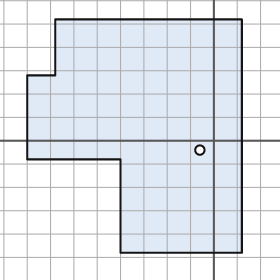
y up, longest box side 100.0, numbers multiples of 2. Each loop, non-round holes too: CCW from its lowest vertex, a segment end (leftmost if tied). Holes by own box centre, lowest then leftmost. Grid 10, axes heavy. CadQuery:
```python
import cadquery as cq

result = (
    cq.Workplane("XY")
    .moveTo(-40.0, -48.0)
    .lineTo(12.0, -48.0)
    .lineTo(12.0, 52.0)
    .lineTo(-68.0, 52.0)
    .lineTo(-68.0, 28.0)
    .lineTo(-80.0, 28.0)
    .lineTo(-80.0, -8.0)
    .lineTo(-40.0, -8.0)
    .close()
    .moveTo(-6.0, -4.0)
    .circle(2.0)
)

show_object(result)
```